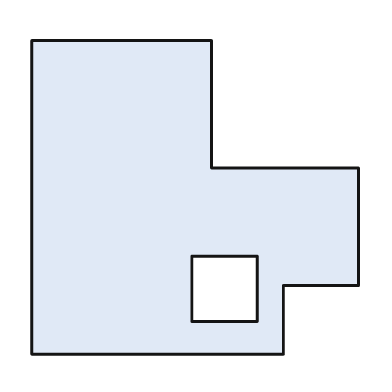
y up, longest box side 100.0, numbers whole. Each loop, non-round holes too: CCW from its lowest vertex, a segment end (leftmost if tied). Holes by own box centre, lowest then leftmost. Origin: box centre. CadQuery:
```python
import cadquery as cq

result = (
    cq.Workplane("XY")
    .moveTo(-50.0, -48.0)
    .lineTo(27.0, -48.0)
    .lineTo(27.0, -27.0)
    .lineTo(50.0, -27.0)
    .lineTo(50.0, 9.0)
    .lineTo(5.0, 9.0)
    .lineTo(5.0, 48.0)
    .lineTo(-50.0, 48.0)
    .close()
    .moveTo(-1.0, -38.0)
    .lineTo(19.0, -38.0)
    .lineTo(19.0, -18.0)
    .lineTo(-1.0, -18.0)
    .close()
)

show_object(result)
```